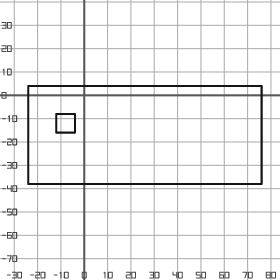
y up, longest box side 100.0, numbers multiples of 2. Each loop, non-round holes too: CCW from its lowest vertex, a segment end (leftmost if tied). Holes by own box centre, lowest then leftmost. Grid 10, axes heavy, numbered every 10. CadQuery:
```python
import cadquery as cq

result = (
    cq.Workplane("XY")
    .moveTo(-24.0, -38.0)
    .lineTo(76.0, -38.0)
    .lineTo(76.0, 4.0)
    .lineTo(-24.0, 4.0)
    .close()
    .moveTo(-12.0, -16.0)
    .lineTo(-4.0, -16.0)
    .lineTo(-4.0, -8.0)
    .lineTo(-12.0, -8.0)
    .close()
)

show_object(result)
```